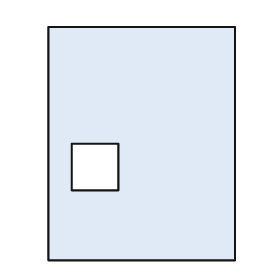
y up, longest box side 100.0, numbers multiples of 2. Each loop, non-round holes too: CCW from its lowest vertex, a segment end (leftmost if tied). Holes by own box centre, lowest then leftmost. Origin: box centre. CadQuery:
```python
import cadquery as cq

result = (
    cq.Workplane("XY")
    .moveTo(-40.0, -50.0)
    .lineTo(40.0, -50.0)
    .lineTo(40.0, 50.0)
    .lineTo(-40.0, 50.0)
    .close()
    .moveTo(-30.0, -20.0)
    .lineTo(-10.0, -20.0)
    .lineTo(-10.0, 0.0)
    .lineTo(-30.0, 0.0)
    .close()
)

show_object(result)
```